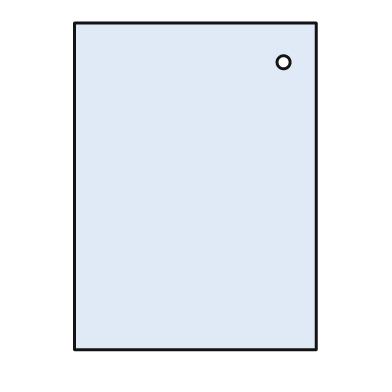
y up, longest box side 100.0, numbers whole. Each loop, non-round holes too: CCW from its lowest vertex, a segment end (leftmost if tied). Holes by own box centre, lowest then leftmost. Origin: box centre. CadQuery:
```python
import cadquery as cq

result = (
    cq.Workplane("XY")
    .moveTo(-37.0, -50.0)
    .lineTo(37.0, -50.0)
    .lineTo(37.0, 50.0)
    .lineTo(-37.0, 50.0)
    .close()
    .moveTo(27.0, 38.0)
    .circle(2.0)
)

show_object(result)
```